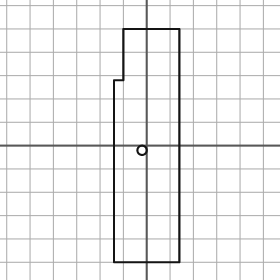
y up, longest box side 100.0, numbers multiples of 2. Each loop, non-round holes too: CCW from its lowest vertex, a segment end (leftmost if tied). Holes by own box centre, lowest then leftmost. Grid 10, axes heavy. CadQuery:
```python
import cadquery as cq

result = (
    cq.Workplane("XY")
    .moveTo(-14.0, -50.0)
    .lineTo(14.0, -50.0)
    .lineTo(14.0, 50.0)
    .lineTo(-10.0, 50.0)
    .lineTo(-10.0, 28.0)
    .lineTo(-14.0, 28.0)
    .close()
    .moveTo(-2.0, -2.0)
    .circle(2.0)
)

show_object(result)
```